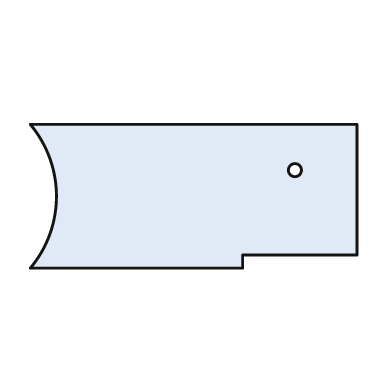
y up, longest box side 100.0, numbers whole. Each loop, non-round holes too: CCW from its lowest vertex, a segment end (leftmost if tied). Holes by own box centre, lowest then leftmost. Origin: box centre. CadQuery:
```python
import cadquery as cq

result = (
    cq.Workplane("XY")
    .moveTo(-50.0, -22.0)
    .lineTo(15.0, -22.0)
    .lineTo(15.0, -18.0)
    .lineTo(50.0, -18.0)
    .lineTo(50.0, 22.0)
    .lineTo(-50.0, 22.0)
    .threePointArc((-42.0, 0.0), (-50.0, -22.0))
    .close()
    .moveTo(31.0, 8.0)
    .circle(2.0)
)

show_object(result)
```